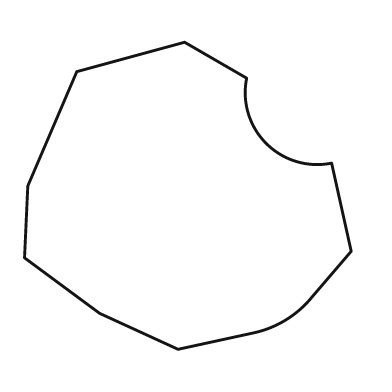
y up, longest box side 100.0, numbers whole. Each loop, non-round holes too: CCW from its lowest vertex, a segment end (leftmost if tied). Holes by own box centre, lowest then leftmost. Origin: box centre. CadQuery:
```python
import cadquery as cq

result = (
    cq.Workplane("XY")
    .moveTo(-3.0, -47.0)
    .lineTo(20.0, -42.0)
    .threePointArc((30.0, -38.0), (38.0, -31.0))
    .lineTo(50.0, -17.0)
    .lineTo(44.0, 10.0)
    .threePointArc((24.0, 16.0), (18.0, 36.0))
    .lineTo(-1.0, 47.0)
    .lineTo(-34.0, 38.0)
    .lineTo(-49.0, 3.0)
    .lineTo(-50.0, -19.0)
    .lineTo(-27.0, -36.0)
    .close()
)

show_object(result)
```